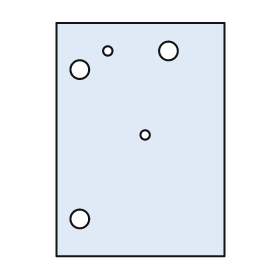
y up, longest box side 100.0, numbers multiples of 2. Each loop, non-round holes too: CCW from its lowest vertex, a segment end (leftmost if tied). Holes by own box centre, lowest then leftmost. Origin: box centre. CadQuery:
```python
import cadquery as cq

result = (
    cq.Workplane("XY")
    .moveTo(-36.0, -50.0)
    .lineTo(36.0, -50.0)
    .lineTo(36.0, 50.0)
    .lineTo(-36.0, 50.0)
    .close()
    .moveTo(-26.0, -34.0)
    .circle(4.0)
    .moveTo(2.0, 2.0)
    .circle(2.0)
    .moveTo(-26.0, 30.0)
    .circle(4.0)
    .moveTo(-14.0, 38.0)
    .circle(2.0)
    .moveTo(12.0, 38.0)
    .circle(4.0)
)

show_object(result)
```